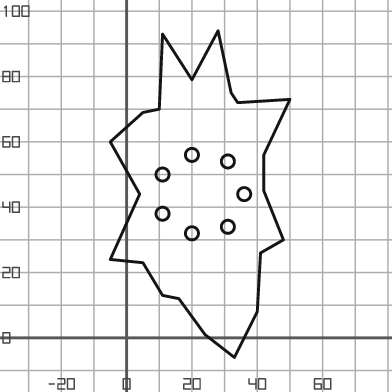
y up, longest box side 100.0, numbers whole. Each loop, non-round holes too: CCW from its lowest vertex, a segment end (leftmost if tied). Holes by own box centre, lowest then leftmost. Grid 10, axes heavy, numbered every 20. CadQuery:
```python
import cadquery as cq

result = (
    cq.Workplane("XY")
    .moveTo(33.0, -6.0)
    .lineTo(40.0, 8.0)
    .lineTo(41.0, 26.0)
    .lineTo(48.0, 30.0)
    .lineTo(42.0, 45.0)
    .lineTo(42.0, 56.0)
    .lineTo(50.0, 73.0)
    .lineTo(34.0, 72.0)
    .lineTo(32.0, 75.0)
    .lineTo(28.0, 94.0)
    .lineTo(20.0, 79.0)
    .lineTo(11.0, 93.0)
    .lineTo(10.0, 70.0)
    .lineTo(5.0, 69.0)
    .lineTo(-5.0, 60.0)
    .lineTo(4.0, 44.0)
    .lineTo(-5.0, 24.0)
    .lineTo(5.0, 23.0)
    .lineTo(11.0, 13.0)
    .lineTo(16.0, 12.0)
    .lineTo(24.0, 1.0)
    .close()
    .moveTo(20.0, 32.0)
    .circle(2.0)
    .moveTo(31.0, 34.0)
    .circle(2.0)
    .moveTo(11.0, 38.0)
    .circle(2.0)
    .moveTo(36.0, 44.0)
    .circle(2.0)
    .moveTo(11.0, 50.0)
    .circle(2.0)
    .moveTo(31.0, 54.0)
    .circle(2.0)
    .moveTo(20.0, 56.0)
    .circle(2.0)
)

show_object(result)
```